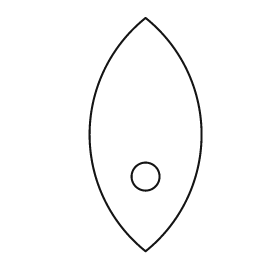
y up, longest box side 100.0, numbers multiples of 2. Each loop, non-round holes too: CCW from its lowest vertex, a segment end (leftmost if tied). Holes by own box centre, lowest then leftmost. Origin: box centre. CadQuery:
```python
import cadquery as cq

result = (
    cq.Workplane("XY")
    .moveTo(0.0, -50.0)
    .threePointArc((24.0, 0.0), (0.0, 50.0))
    .threePointArc((-24.0, 0.0), (0.0, -50.0))
    .close()
    .moveTo(0.0, -18.0)
    .circle(6.0)
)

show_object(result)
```